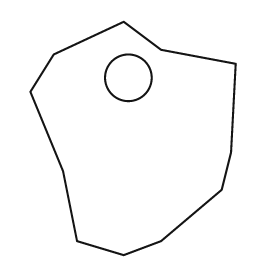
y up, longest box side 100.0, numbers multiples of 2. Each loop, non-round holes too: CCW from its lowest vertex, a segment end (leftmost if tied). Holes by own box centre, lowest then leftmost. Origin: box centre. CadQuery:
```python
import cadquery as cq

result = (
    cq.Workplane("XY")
    .moveTo(-4.0, -50.0)
    .lineTo(12.0, -44.0)
    .lineTo(38.0, -22.0)
    .lineTo(42.0, -6.0)
    .lineTo(44.0, 32.0)
    .lineTo(12.0, 38.0)
    .lineTo(-4.0, 50.0)
    .lineTo(-34.0, 36.0)
    .lineTo(-44.0, 20.0)
    .lineTo(-30.0, -14.0)
    .lineTo(-24.0, -44.0)
    .close()
    .moveTo(-2.0, 26.0)
    .circle(10.0)
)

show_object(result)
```